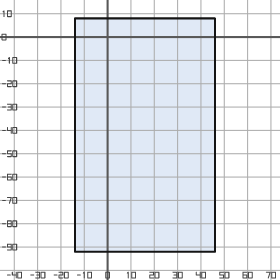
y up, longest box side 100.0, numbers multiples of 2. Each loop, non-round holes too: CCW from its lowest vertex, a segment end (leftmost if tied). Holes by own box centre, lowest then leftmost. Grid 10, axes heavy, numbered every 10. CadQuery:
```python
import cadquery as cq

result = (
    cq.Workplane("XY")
    .moveTo(-14.0, -92.0)
    .lineTo(46.0, -92.0)
    .lineTo(46.0, 8.0)
    .lineTo(-14.0, 8.0)
    .close()
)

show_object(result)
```